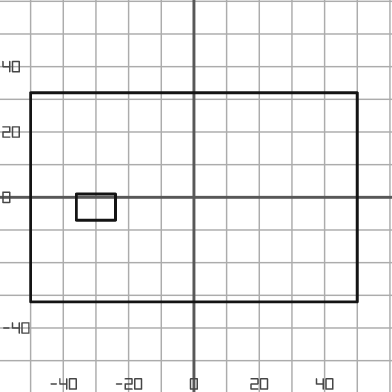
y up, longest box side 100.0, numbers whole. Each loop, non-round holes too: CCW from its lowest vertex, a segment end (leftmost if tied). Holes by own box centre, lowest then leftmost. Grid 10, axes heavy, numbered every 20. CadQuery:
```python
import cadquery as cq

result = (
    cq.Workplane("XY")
    .moveTo(-50.0, -32.0)
    .lineTo(50.0, -32.0)
    .lineTo(50.0, 32.0)
    .lineTo(-50.0, 32.0)
    .close()
    .moveTo(-36.0, -7.0)
    .lineTo(-24.0, -7.0)
    .lineTo(-24.0, 1.0)
    .lineTo(-36.0, 1.0)
    .close()
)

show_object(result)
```